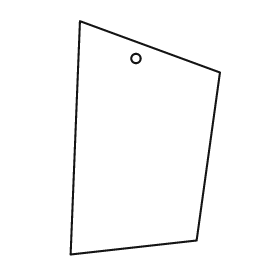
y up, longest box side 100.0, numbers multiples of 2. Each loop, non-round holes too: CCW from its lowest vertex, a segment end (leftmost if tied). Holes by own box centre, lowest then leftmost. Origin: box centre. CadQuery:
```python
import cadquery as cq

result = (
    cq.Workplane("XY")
    .moveTo(-32.0, -50.0)
    .lineTo(22.0, -44.0)
    .lineTo(32.0, 28.0)
    .lineTo(-28.0, 50.0)
    .close()
    .moveTo(-4.0, 34.0)
    .circle(2.0)
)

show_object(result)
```